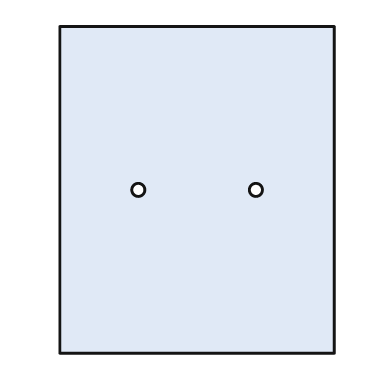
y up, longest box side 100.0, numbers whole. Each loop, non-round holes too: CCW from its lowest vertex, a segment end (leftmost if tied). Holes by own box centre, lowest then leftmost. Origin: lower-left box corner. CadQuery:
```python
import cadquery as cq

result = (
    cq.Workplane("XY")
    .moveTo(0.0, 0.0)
    .lineTo(84.0, 0.0)
    .lineTo(84.0, 100.0)
    .lineTo(0.0, 100.0)
    .close()
    .moveTo(24.0, 50.0)
    .circle(2.0)
    .moveTo(60.0, 50.0)
    .circle(2.0)
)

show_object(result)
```